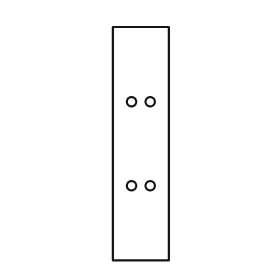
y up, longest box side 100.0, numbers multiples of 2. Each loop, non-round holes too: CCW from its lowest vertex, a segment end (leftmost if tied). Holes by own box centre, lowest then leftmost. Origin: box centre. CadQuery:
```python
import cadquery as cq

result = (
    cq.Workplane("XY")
    .moveTo(-12.0, -50.0)
    .lineTo(12.0, -50.0)
    .lineTo(12.0, 50.0)
    .lineTo(-12.0, 50.0)
    .close()
    .moveTo(-4.0, -18.0)
    .circle(2.0)
    .moveTo(4.0, -18.0)
    .circle(2.0)
    .moveTo(-4.0, 18.0)
    .circle(2.0)
    .moveTo(4.0, 18.0)
    .circle(2.0)
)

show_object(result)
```